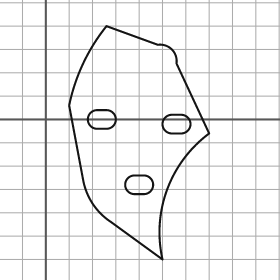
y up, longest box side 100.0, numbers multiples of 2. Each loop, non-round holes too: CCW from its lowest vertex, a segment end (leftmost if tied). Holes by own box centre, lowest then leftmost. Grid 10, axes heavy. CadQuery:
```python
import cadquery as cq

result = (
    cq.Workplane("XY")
    .moveTo(50.0, -60.0)
    .threePointArc((52.0, -30.0), (70.0, -6.0))
    .lineTo(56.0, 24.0)
    .threePointArc((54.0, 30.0), (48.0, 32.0))
    .lineTo(26.0, 40.0)
    .threePointArc((16.0, 24.0), (10.0, 6.0))
    .lineTo(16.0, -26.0)
    .threePointArc((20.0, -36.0), (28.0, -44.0))
    .close()
    .moveTo(38.0, -32.0)
    .lineTo(42.0, -32.0)
    .threePointArc((46.0, -28.0), (42.0, -24.0))
    .lineTo(38.0, -24.0)
    .threePointArc((34.0, -28.0), (38.0, -32.0))
    .close()
    .moveTo(54.0, -6.0)
    .lineTo(58.0, -6.0)
    .threePointArc((62.0, -2.0), (58.0, 2.0))
    .lineTo(54.0, 2.0)
    .threePointArc((50.0, -2.0), (54.0, -6.0))
    .close()
    .moveTo(22.0, -4.0)
    .lineTo(26.0, -4.0)
    .threePointArc((30.0, 0.0), (26.0, 4.0))
    .lineTo(22.0, 4.0)
    .threePointArc((18.0, 0.0), (22.0, -4.0))
    .close()
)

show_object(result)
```